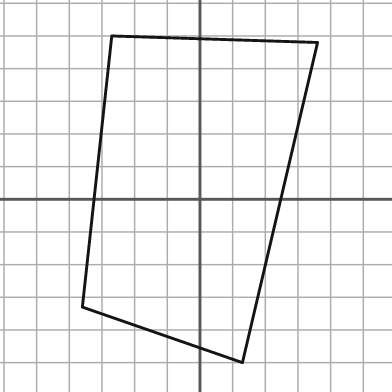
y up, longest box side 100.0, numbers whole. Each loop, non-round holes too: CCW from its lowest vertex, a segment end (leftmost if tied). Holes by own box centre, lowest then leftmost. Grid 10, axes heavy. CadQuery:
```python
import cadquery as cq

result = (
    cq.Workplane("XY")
    .moveTo(13.0, -50.0)
    .lineTo(36.0, 48.0)
    .lineTo(-27.0, 50.0)
    .lineTo(-36.0, -33.0)
    .close()
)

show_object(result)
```